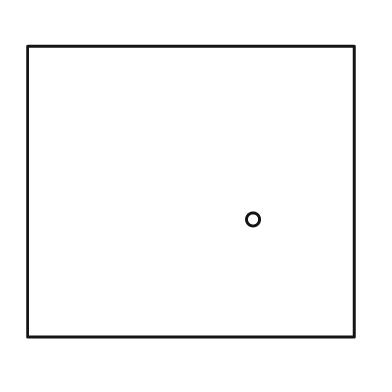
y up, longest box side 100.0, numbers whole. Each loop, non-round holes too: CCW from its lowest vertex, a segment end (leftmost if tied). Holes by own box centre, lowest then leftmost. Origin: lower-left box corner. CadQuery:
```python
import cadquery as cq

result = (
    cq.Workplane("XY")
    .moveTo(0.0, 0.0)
    .lineTo(100.0, 0.0)
    .lineTo(100.0, 89.0)
    .lineTo(0.0, 89.0)
    .close()
    .moveTo(69.0, 36.0)
    .circle(2.0)
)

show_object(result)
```